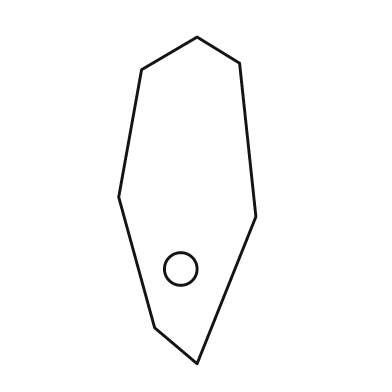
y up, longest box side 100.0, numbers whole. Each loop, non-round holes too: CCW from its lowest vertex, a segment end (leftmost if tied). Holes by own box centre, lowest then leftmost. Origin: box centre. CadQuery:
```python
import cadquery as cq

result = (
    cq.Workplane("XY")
    .moveTo(3.0, -50.0)
    .lineTo(21.0, -5.0)
    .lineTo(16.0, 42.0)
    .lineTo(3.0, 50.0)
    .lineTo(-14.0, 40.0)
    .lineTo(-21.0, 1.0)
    .lineTo(-10.0, -39.0)
    .close()
    .moveTo(-2.0, -21.0)
    .circle(5.0)
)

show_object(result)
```